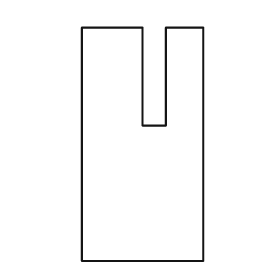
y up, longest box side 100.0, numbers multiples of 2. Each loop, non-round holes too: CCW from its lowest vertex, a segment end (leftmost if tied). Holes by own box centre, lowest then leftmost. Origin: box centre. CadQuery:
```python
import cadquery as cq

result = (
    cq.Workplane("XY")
    .moveTo(-26.0, -50.0)
    .lineTo(26.0, -50.0)
    .lineTo(26.0, 50.0)
    .lineTo(10.0, 50.0)
    .lineTo(10.0, 8.0)
    .lineTo(0.0, 8.0)
    .lineTo(0.0, 50.0)
    .lineTo(-26.0, 50.0)
    .close()
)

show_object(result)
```